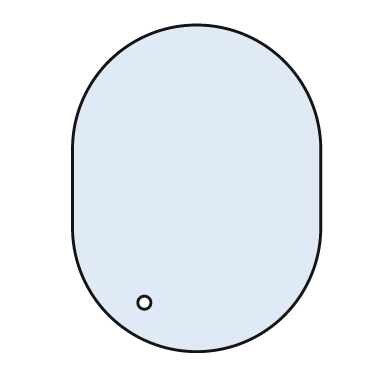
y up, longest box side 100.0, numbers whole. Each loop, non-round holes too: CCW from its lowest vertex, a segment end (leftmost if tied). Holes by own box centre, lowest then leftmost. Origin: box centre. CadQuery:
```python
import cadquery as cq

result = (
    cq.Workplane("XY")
    .moveTo(-38.0, -12.0)
    .threePointArc((0.0, -50.0), (38.0, -12.0))
    .lineTo(38.0, 12.0)
    .threePointArc((0.0, 50.0), (-38.0, 12.0))
    .close()
    .moveTo(-16.0, -35.0)
    .circle(2.0)
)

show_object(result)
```